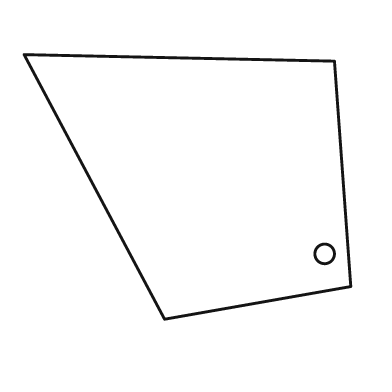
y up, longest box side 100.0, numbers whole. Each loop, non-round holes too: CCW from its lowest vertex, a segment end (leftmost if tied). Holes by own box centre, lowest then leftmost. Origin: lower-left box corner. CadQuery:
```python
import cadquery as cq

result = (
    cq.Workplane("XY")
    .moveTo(43.0, 0.0)
    .lineTo(100.0, 10.0)
    .lineTo(95.0, 79.0)
    .lineTo(0.0, 81.0)
    .close()
    .moveTo(92.0, 20.0)
    .circle(3.0)
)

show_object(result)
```